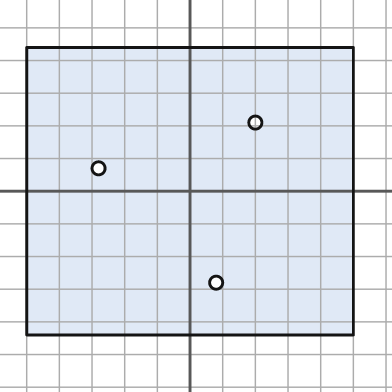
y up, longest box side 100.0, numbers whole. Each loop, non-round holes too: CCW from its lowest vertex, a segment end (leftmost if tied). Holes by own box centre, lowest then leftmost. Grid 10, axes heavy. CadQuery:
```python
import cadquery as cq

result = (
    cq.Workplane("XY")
    .moveTo(-50.0, -44.0)
    .lineTo(50.0, -44.0)
    .lineTo(50.0, 44.0)
    .lineTo(-50.0, 44.0)
    .close()
    .moveTo(8.0, -28.0)
    .circle(2.0)
    .moveTo(-28.0, 7.0)
    .circle(2.0)
    .moveTo(20.0, 21.0)
    .circle(2.0)
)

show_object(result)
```